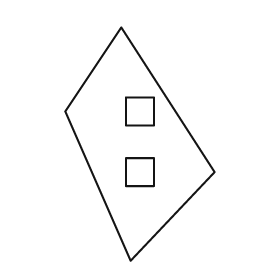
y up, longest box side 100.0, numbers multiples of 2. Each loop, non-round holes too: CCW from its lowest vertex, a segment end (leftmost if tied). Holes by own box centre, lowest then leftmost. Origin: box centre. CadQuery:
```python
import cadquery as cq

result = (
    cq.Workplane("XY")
    .moveTo(-4.0, -50.0)
    .lineTo(32.0, -12.0)
    .lineTo(-8.0, 50.0)
    .lineTo(-32.0, 14.0)
    .close()
    .moveTo(-6.0, -18.0)
    .lineTo(6.0, -18.0)
    .lineTo(6.0, -6.0)
    .lineTo(-6.0, -6.0)
    .close()
    .moveTo(-6.0, 8.0)
    .lineTo(6.0, 8.0)
    .lineTo(6.0, 20.0)
    .lineTo(-6.0, 20.0)
    .close()
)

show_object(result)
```